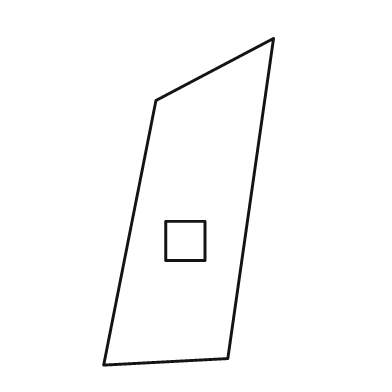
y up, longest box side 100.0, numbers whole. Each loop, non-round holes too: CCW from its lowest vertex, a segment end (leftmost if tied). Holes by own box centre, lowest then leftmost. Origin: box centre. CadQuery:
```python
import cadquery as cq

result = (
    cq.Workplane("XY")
    .moveTo(-26.0, -50.0)
    .lineTo(12.0, -48.0)
    .lineTo(26.0, 50.0)
    .lineTo(-10.0, 31.0)
    .close()
    .moveTo(-7.0, -18.0)
    .lineTo(5.0, -18.0)
    .lineTo(5.0, -6.0)
    .lineTo(-7.0, -6.0)
    .close()
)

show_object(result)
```